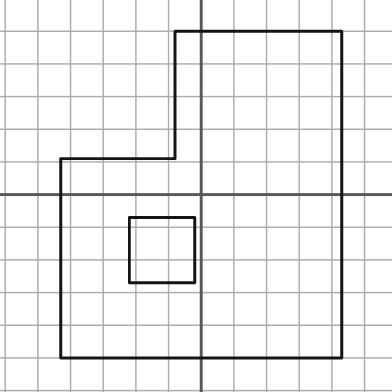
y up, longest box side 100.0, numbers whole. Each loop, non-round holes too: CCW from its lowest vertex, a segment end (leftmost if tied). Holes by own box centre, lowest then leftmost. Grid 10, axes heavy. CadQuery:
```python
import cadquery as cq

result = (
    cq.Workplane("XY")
    .moveTo(-43.0, -50.0)
    .lineTo(43.0, -50.0)
    .lineTo(43.0, 50.0)
    .lineTo(-8.0, 50.0)
    .lineTo(-8.0, 11.0)
    .lineTo(-43.0, 11.0)
    .close()
    .moveTo(-22.0, -27.0)
    .lineTo(-2.0, -27.0)
    .lineTo(-2.0, -7.0)
    .lineTo(-22.0, -7.0)
    .close()
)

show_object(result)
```